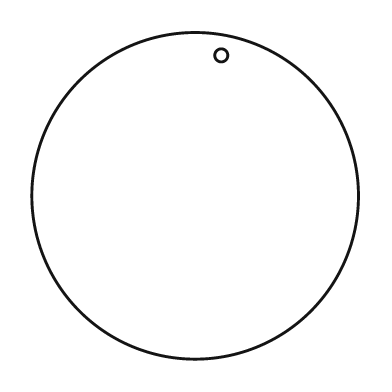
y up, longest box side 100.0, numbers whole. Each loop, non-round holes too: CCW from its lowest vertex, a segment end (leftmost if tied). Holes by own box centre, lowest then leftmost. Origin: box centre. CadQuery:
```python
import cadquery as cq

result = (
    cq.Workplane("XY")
    .moveTo(0.0, 0.0)
    .circle(50.0)
    .moveTo(8.0, 43.0)
    .circle(2.0)
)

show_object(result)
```